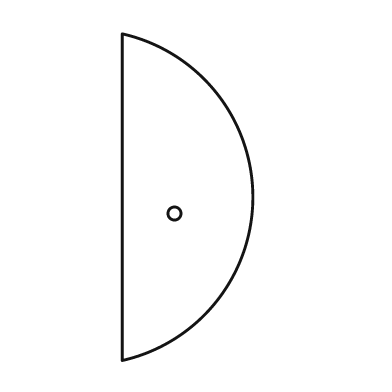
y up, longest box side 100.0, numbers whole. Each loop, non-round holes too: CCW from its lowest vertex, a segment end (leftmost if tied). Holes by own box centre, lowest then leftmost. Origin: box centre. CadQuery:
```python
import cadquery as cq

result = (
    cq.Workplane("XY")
    .moveTo(-20.0, -50.0)
    .threePointArc((20.0, 0.0), (-20.0, 50.0))
    .close()
    .moveTo(-4.0, -5.0)
    .circle(2.0)
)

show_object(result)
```